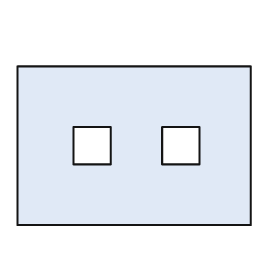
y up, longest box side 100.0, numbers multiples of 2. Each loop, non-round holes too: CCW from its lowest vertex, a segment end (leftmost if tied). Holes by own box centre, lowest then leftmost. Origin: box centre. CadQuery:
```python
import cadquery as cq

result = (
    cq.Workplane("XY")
    .moveTo(-50.0, -34.0)
    .lineTo(50.0, -34.0)
    .lineTo(50.0, 34.0)
    .lineTo(-50.0, 34.0)
    .close()
    .moveTo(-26.0, -8.0)
    .lineTo(-10.0, -8.0)
    .lineTo(-10.0, 8.0)
    .lineTo(-26.0, 8.0)
    .close()
    .moveTo(12.0, -8.0)
    .lineTo(28.0, -8.0)
    .lineTo(28.0, 8.0)
    .lineTo(12.0, 8.0)
    .close()
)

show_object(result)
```